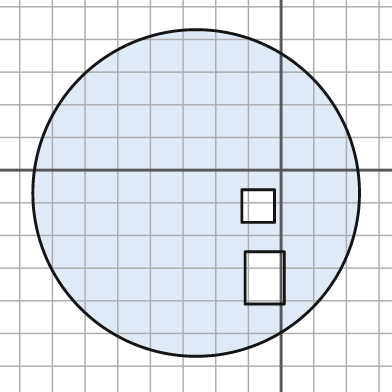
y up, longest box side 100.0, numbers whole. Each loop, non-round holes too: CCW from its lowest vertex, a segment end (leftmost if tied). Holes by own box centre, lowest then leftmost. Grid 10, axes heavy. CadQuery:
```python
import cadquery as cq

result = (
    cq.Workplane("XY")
    .moveTo(-26.0, -7.0)
    .circle(50.0)
    .moveTo(-11.0, -41.0)
    .lineTo(1.0, -41.0)
    .lineTo(1.0, -25.0)
    .lineTo(-11.0, -25.0)
    .close()
    .moveTo(-12.0, -16.0)
    .lineTo(-2.0, -16.0)
    .lineTo(-2.0, -6.0)
    .lineTo(-12.0, -6.0)
    .close()
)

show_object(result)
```